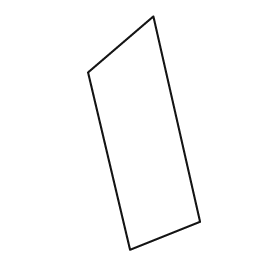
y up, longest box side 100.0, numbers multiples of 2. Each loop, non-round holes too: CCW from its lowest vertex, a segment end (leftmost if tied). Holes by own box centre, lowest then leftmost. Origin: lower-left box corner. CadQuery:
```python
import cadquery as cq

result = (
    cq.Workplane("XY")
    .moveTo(18.0, 0.0)
    .lineTo(48.0, 12.0)
    .lineTo(28.0, 100.0)
    .lineTo(0.0, 76.0)
    .close()
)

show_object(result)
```